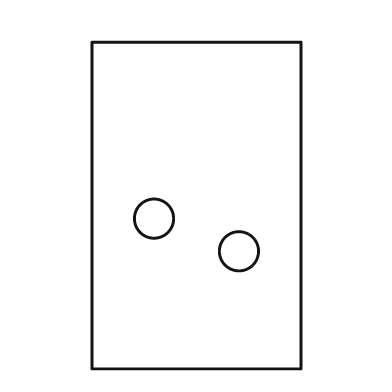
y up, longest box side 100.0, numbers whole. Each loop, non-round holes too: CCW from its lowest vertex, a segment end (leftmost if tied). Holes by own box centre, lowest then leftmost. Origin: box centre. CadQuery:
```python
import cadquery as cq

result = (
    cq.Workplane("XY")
    .moveTo(-32.0, -50.0)
    .lineTo(32.0, -50.0)
    .lineTo(32.0, 50.0)
    .lineTo(-32.0, 50.0)
    .close()
    .moveTo(13.0, -14.0)
    .circle(6.0)
    .moveTo(-13.0, -4.0)
    .circle(6.0)
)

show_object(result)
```